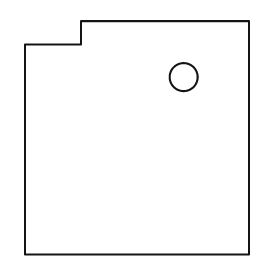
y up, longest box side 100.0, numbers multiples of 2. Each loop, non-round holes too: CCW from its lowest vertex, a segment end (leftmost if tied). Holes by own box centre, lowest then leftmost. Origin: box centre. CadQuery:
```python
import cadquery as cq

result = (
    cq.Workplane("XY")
    .moveTo(-48.0, -50.0)
    .lineTo(48.0, -50.0)
    .lineTo(48.0, 50.0)
    .lineTo(-24.0, 50.0)
    .lineTo(-24.0, 40.0)
    .lineTo(-48.0, 40.0)
    .close()
    .moveTo(20.0, 26.0)
    .circle(6.0)
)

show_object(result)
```